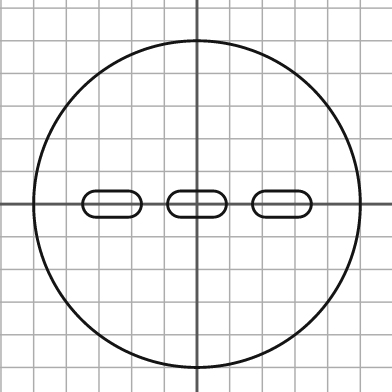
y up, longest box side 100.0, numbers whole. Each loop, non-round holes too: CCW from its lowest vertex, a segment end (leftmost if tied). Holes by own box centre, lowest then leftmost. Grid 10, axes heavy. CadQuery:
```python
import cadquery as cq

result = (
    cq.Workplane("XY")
    .moveTo(0.0, 0.0)
    .circle(50.0)
    .moveTo(-31.0, -4.0)
    .lineTo(-21.0, -4.0)
    .threePointArc((-17.0, 0.0), (-21.0, 4.0))
    .lineTo(-31.0, 4.0)
    .threePointArc((-35.0, 0.0), (-31.0, -4.0))
    .close()
    .moveTo(-5.0, -4.0)
    .lineTo(5.0, -4.0)
    .threePointArc((9.0, 0.0), (5.0, 4.0))
    .lineTo(-5.0, 4.0)
    .threePointArc((-9.0, 0.0), (-5.0, -4.0))
    .close()
    .moveTo(21.0, -4.0)
    .lineTo(31.0, -4.0)
    .threePointArc((35.0, 0.0), (31.0, 4.0))
    .lineTo(21.0, 4.0)
    .threePointArc((17.0, 0.0), (21.0, -4.0))
    .close()
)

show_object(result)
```